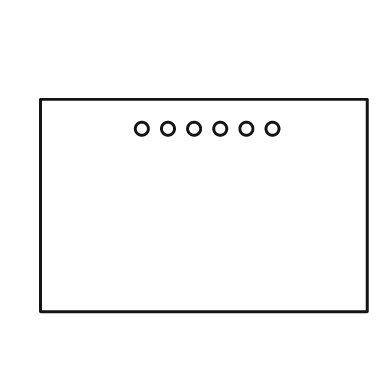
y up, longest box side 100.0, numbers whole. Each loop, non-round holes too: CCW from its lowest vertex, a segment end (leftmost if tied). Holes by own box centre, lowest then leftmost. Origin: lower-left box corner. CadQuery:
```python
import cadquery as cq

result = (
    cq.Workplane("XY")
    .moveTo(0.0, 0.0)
    .lineTo(100.0, 0.0)
    .lineTo(100.0, 65.0)
    .lineTo(0.0, 65.0)
    .close()
    .moveTo(31.0, 56.0)
    .circle(2.0)
    .moveTo(39.0, 56.0)
    .circle(2.0)
    .moveTo(47.0, 56.0)
    .circle(2.0)
    .moveTo(55.0, 56.0)
    .circle(2.0)
    .moveTo(63.0, 56.0)
    .circle(2.0)
    .moveTo(71.0, 56.0)
    .circle(2.0)
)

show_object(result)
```